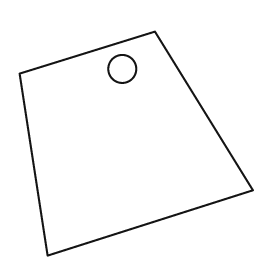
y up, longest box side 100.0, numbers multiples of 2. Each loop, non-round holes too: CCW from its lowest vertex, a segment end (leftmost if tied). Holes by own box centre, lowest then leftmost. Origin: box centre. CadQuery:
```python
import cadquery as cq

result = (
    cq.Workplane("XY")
    .moveTo(-38.0, -48.0)
    .lineTo(50.0, -20.0)
    .lineTo(8.0, 48.0)
    .lineTo(-50.0, 30.0)
    .close()
    .moveTo(-6.0, 32.0)
    .circle(6.0)
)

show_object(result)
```